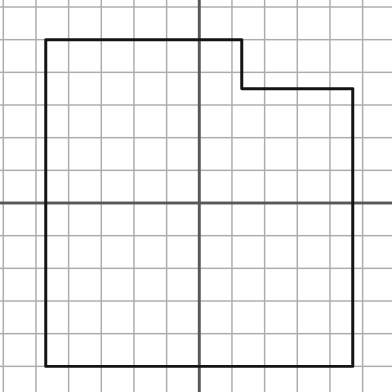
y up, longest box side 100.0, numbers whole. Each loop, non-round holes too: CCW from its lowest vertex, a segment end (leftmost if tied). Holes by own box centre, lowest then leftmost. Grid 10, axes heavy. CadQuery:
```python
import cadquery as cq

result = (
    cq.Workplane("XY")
    .moveTo(-47.0, -50.0)
    .lineTo(47.0, -50.0)
    .lineTo(47.0, 35.0)
    .lineTo(13.0, 35.0)
    .lineTo(13.0, 50.0)
    .lineTo(-47.0, 50.0)
    .close()
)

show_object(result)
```